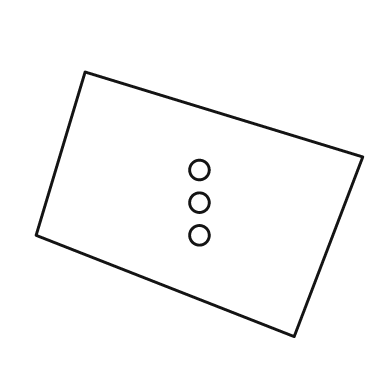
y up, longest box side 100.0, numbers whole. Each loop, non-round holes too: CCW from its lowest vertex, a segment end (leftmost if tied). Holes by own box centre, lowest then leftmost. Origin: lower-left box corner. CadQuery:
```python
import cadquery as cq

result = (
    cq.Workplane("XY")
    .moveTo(79.0, 0.0)
    .lineTo(100.0, 55.0)
    .lineTo(15.0, 81.0)
    .lineTo(0.0, 31.0)
    .close()
    .moveTo(50.0, 31.0)
    .circle(3.0)
    .moveTo(50.0, 41.0)
    .circle(3.0)
    .moveTo(50.0, 51.0)
    .circle(3.0)
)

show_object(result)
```